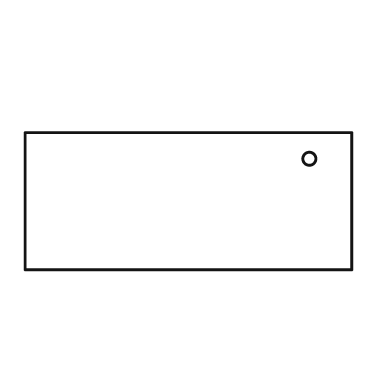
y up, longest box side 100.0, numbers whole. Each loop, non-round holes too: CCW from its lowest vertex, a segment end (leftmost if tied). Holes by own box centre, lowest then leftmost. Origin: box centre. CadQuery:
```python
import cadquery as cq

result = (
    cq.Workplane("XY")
    .moveTo(-50.0, -21.0)
    .lineTo(50.0, -21.0)
    .lineTo(50.0, 21.0)
    .lineTo(-50.0, 21.0)
    .close()
    .moveTo(37.0, 13.0)
    .circle(2.0)
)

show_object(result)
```